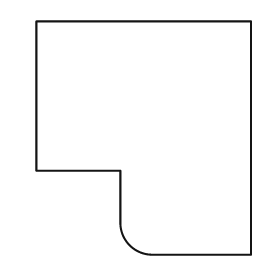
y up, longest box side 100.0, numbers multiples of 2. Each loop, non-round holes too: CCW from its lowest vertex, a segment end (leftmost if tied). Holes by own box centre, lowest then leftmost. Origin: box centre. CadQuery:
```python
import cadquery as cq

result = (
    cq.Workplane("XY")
    .moveTo(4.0, -50.0)
    .lineTo(46.0, -50.0)
    .lineTo(46.0, 50.0)
    .lineTo(-46.0, 50.0)
    .lineTo(-46.0, -14.0)
    .lineTo(-10.0, -14.0)
    .lineTo(-10.0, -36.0)
    .threePointArc((-6.0, -46.0), (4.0, -50.0))
    .close()
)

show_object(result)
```